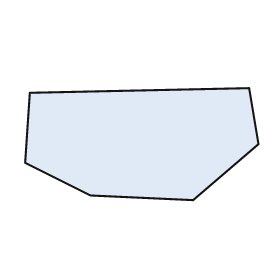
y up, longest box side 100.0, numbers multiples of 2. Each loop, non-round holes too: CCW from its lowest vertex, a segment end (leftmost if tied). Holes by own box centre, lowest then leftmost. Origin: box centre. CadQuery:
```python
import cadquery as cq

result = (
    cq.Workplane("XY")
    .moveTo(22.0, -24.0)
    .lineTo(50.0, 0.0)
    .lineTo(46.0, 24.0)
    .lineTo(-48.0, 22.0)
    .lineTo(-50.0, -8.0)
    .lineTo(-22.0, -22.0)
    .close()
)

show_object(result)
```